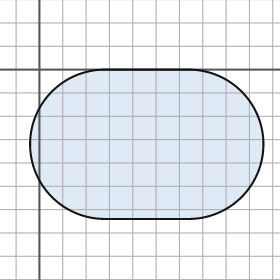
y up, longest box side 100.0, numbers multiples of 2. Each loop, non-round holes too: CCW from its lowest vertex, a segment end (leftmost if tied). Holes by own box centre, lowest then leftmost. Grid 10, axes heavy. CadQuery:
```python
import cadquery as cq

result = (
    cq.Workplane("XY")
    .moveTo(28.0, -64.0)
    .lineTo(64.0, -64.0)
    .threePointArc((96.0, -32.0), (64.0, 0.0))
    .lineTo(28.0, 0.0)
    .threePointArc((-4.0, -32.0), (28.0, -64.0))
    .close()
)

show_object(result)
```